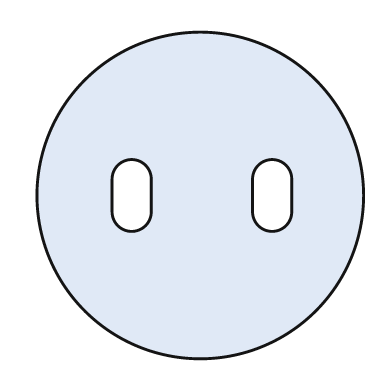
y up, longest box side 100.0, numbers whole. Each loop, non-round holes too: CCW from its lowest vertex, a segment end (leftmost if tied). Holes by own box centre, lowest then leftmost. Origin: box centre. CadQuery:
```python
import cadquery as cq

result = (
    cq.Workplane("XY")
    .moveTo(0.0, 0.0)
    .circle(50.0)
    .moveTo(-27.0, -5.0)
    .threePointArc((-21.0, -11.0), (-15.0, -5.0))
    .lineTo(-15.0, 5.0)
    .threePointArc((-21.0, 11.0), (-27.0, 5.0))
    .close()
    .moveTo(16.0, -5.0)
    .threePointArc((22.0, -11.0), (28.0, -5.0))
    .lineTo(28.0, 5.0)
    .threePointArc((22.0, 11.0), (16.0, 5.0))
    .close()
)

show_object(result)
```